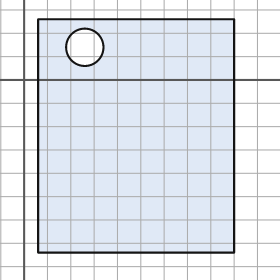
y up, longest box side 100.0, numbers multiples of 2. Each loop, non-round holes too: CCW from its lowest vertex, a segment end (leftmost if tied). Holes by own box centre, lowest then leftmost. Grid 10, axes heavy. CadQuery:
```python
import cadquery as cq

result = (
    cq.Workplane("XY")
    .moveTo(6.0, -74.0)
    .lineTo(90.0, -74.0)
    .lineTo(90.0, 26.0)
    .lineTo(6.0, 26.0)
    .close()
    .moveTo(26.0, 14.0)
    .circle(8.0)
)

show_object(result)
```